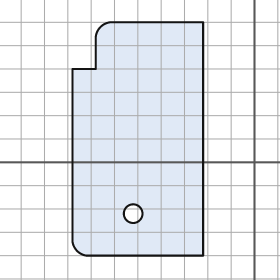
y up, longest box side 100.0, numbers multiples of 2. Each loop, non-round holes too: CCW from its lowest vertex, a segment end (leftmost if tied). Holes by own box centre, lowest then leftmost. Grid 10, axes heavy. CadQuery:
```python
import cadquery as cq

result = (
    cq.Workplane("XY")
    .moveTo(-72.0, -40.0)
    .lineTo(-22.0, -40.0)
    .lineTo(-22.0, 60.0)
    .lineTo(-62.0, 60.0)
    .threePointArc((-66.0, 58.0), (-68.0, 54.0))
    .lineTo(-68.0, 40.0)
    .lineTo(-78.0, 40.0)
    .lineTo(-78.0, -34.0)
    .threePointArc((-76.0, -38.0), (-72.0, -40.0))
    .close()
    .moveTo(-52.0, -22.0)
    .circle(4.0)
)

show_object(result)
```